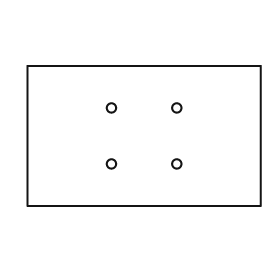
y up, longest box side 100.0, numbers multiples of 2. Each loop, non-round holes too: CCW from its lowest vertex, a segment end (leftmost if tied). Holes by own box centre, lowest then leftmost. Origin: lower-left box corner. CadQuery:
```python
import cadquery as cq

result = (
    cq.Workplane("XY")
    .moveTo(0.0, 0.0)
    .lineTo(100.0, 0.0)
    .lineTo(100.0, 60.0)
    .lineTo(0.0, 60.0)
    .close()
    .moveTo(36.0, 18.0)
    .circle(2.0)
    .moveTo(64.0, 18.0)
    .circle(2.0)
    .moveTo(36.0, 42.0)
    .circle(2.0)
    .moveTo(64.0, 42.0)
    .circle(2.0)
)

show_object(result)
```